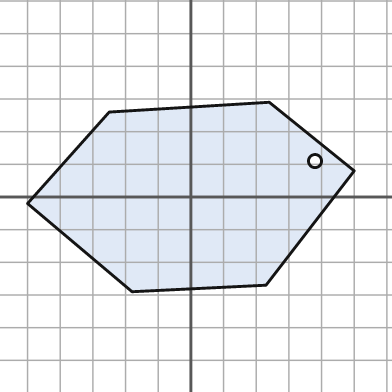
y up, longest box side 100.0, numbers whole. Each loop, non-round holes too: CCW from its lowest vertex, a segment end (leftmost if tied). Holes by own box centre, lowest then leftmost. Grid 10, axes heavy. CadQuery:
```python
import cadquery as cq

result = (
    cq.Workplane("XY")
    .moveTo(-18.0, -29.0)
    .lineTo(23.0, -27.0)
    .lineTo(50.0, 8.0)
    .lineTo(24.0, 29.0)
    .lineTo(-25.0, 26.0)
    .lineTo(-50.0, -2.0)
    .close()
    .moveTo(38.0, 11.0)
    .circle(2.0)
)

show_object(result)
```